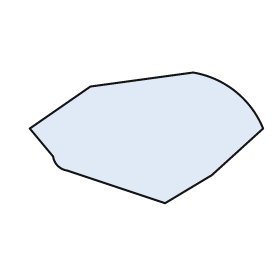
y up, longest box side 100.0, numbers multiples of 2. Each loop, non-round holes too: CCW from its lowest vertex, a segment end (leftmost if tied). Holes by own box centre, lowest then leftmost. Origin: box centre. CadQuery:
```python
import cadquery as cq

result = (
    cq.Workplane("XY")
    .moveTo(8.0, -28.0)
    .lineTo(28.0, -16.0)
    .lineTo(50.0, 4.0)
    .threePointArc((38.0, 20.0), (20.0, 28.0))
    .lineTo(-24.0, 22.0)
    .lineTo(-50.0, 4.0)
    .lineTo(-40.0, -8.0)
    .threePointArc((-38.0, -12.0), (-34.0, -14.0))
    .close()
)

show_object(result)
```